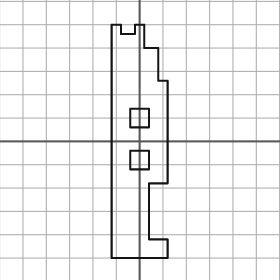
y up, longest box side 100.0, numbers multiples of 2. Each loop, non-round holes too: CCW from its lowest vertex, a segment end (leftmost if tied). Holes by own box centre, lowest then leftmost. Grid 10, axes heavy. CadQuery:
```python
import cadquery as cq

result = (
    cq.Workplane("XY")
    .moveTo(-12.0, -50.0)
    .lineTo(12.0, -50.0)
    .lineTo(12.0, -42.0)
    .lineTo(4.0, -42.0)
    .lineTo(4.0, -18.0)
    .lineTo(12.0, -18.0)
    .lineTo(12.0, 26.0)
    .lineTo(8.0, 26.0)
    .lineTo(8.0, 40.0)
    .lineTo(2.0, 40.0)
    .lineTo(2.0, 50.0)
    .lineTo(-2.0, 50.0)
    .lineTo(-2.0, 46.0)
    .lineTo(-8.0, 46.0)
    .lineTo(-8.0, 50.0)
    .lineTo(-12.0, 50.0)
    .close()
    .moveTo(-4.0, -12.0)
    .lineTo(4.0, -12.0)
    .lineTo(4.0, -4.0)
    .lineTo(-4.0, -4.0)
    .close()
    .moveTo(-4.0, 6.0)
    .lineTo(4.0, 6.0)
    .lineTo(4.0, 14.0)
    .lineTo(-4.0, 14.0)
    .close()
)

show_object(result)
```